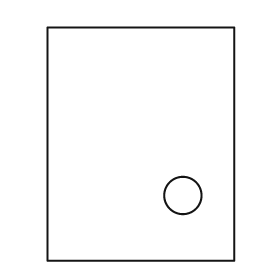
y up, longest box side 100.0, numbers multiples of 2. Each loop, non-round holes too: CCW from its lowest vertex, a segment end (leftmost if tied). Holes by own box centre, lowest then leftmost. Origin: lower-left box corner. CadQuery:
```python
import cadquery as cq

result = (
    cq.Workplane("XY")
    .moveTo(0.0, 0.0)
    .lineTo(80.0, 0.0)
    .lineTo(80.0, 100.0)
    .lineTo(0.0, 100.0)
    .close()
    .moveTo(58.0, 28.0)
    .circle(8.0)
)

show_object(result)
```